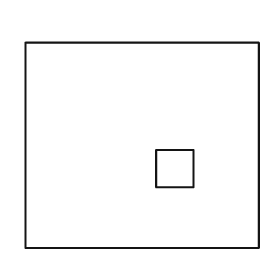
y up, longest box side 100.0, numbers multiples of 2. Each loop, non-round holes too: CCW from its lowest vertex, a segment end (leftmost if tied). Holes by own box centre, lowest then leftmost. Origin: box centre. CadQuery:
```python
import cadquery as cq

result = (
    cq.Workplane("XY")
    .moveTo(-50.0, -44.0)
    .lineTo(50.0, -44.0)
    .lineTo(50.0, 44.0)
    .lineTo(-50.0, 44.0)
    .close()
    .moveTo(6.0, -18.0)
    .lineTo(22.0, -18.0)
    .lineTo(22.0, -2.0)
    .lineTo(6.0, -2.0)
    .close()
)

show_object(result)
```